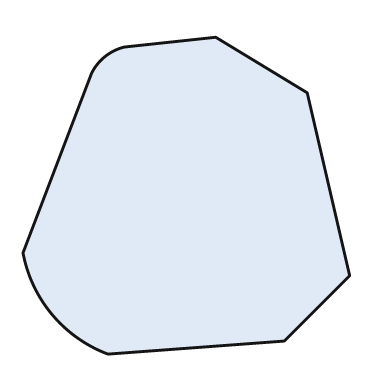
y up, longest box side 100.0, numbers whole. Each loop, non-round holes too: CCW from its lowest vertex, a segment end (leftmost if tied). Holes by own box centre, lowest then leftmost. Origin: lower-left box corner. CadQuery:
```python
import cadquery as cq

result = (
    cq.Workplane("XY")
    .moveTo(26.0, 0.0)
    .lineTo(80.0, 4.0)
    .lineTo(100.0, 24.0)
    .lineTo(87.0, 80.0)
    .lineTo(59.0, 97.0)
    .lineTo(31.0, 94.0)
    .threePointArc((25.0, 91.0), (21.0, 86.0))
    .lineTo(0.0, 31.0)
    .threePointArc((9.0, 12.0), (26.0, 0.0))
    .close()
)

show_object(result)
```